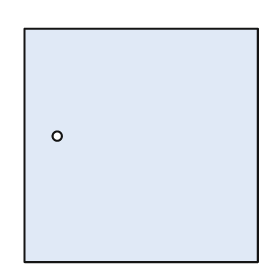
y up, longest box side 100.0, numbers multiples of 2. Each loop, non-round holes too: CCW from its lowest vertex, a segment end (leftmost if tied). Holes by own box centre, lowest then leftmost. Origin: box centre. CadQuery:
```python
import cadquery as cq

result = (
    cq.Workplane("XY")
    .moveTo(-50.0, -50.0)
    .lineTo(50.0, -50.0)
    .lineTo(50.0, 50.0)
    .lineTo(-50.0, 50.0)
    .close()
    .moveTo(-36.0, 4.0)
    .circle(2.0)
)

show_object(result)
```